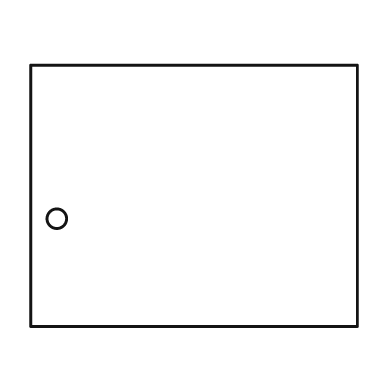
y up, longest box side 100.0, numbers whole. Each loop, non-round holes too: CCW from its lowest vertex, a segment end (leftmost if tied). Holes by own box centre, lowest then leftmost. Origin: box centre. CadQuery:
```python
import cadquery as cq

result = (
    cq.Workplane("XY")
    .moveTo(-50.0, -40.0)
    .lineTo(50.0, -40.0)
    .lineTo(50.0, 40.0)
    .lineTo(-50.0, 40.0)
    .close()
    .moveTo(-42.0, -7.0)
    .circle(3.0)
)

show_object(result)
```